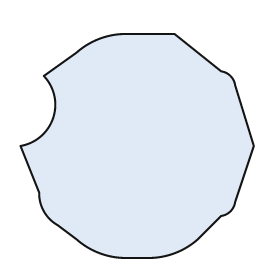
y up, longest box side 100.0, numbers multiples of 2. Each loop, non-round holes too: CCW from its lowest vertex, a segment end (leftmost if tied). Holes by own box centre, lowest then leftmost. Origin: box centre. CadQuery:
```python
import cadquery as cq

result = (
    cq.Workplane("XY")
    .moveTo(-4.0, -48.0)
    .lineTo(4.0, -48.0)
    .threePointArc((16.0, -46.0), (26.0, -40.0))
    .lineTo(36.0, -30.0)
    .threePointArc((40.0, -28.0), (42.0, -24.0))
    .lineTo(50.0, 0.0)
    .lineTo(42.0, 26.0)
    .threePointArc((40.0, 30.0), (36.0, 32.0))
    .lineTo(16.0, 48.0)
    .lineTo(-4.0, 48.0)
    .threePointArc((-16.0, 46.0), (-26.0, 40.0))
    .lineTo(-40.0, 30.0)
    .threePointArc((-36.0, 12.0), (-50.0, 0.0))
    .lineTo(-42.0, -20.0)
    .threePointArc((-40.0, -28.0), (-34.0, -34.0))
    .lineTo(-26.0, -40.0)
    .threePointArc((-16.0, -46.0), (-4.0, -48.0))
    .close()
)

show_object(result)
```